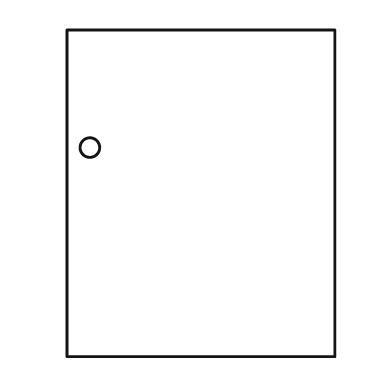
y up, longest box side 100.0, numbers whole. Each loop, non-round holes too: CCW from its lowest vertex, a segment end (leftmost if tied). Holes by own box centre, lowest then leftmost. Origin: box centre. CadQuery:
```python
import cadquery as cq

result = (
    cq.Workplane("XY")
    .moveTo(-41.0, -50.0)
    .lineTo(41.0, -50.0)
    .lineTo(41.0, 50.0)
    .lineTo(-41.0, 50.0)
    .close()
    .moveTo(-34.0, 14.0)
    .circle(3.0)
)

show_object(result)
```